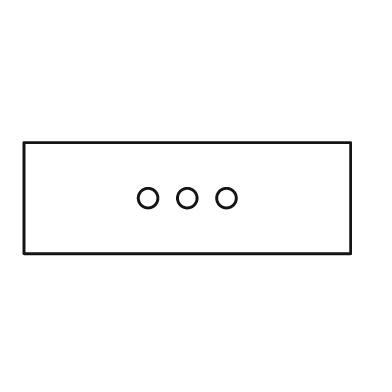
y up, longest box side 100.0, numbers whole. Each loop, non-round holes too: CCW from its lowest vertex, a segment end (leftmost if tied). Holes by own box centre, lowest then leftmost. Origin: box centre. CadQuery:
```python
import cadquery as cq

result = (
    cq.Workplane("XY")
    .moveTo(-50.0, -17.0)
    .lineTo(50.0, -17.0)
    .lineTo(50.0, 17.0)
    .lineTo(-50.0, 17.0)
    .close()
    .moveTo(-12.0, 0.0)
    .circle(3.0)
    .moveTo(0.0, 0.0)
    .circle(3.0)
    .moveTo(12.0, 0.0)
    .circle(3.0)
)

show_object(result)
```